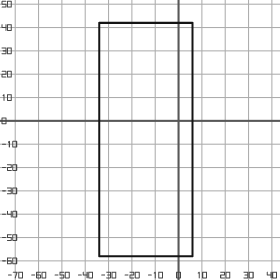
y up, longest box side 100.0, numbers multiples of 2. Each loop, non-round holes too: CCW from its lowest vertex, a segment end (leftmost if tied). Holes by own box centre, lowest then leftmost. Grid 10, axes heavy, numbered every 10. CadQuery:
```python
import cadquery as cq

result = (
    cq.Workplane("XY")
    .moveTo(-34.0, -58.0)
    .lineTo(6.0, -58.0)
    .lineTo(6.0, 42.0)
    .lineTo(-34.0, 42.0)
    .close()
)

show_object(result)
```